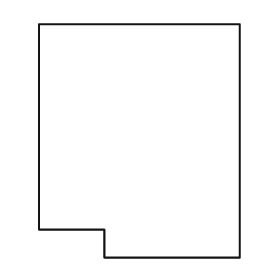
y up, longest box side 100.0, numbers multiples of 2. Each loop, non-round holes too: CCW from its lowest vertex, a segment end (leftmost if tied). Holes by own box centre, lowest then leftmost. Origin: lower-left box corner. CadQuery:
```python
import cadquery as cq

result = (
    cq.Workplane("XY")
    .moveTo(28.0, 0.0)
    .lineTo(86.0, 0.0)
    .lineTo(86.0, 100.0)
    .lineTo(0.0, 100.0)
    .lineTo(0.0, 12.0)
    .lineTo(28.0, 12.0)
    .close()
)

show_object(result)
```